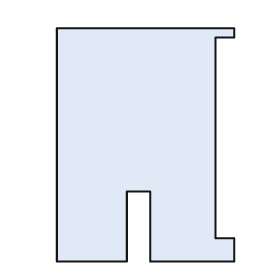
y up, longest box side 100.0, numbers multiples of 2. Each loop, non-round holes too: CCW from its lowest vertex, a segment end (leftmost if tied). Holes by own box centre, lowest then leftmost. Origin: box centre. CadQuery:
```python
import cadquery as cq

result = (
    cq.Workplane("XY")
    .moveTo(-38.0, -50.0)
    .lineTo(-8.0, -50.0)
    .lineTo(-8.0, -20.0)
    .lineTo(2.0, -20.0)
    .lineTo(2.0, -50.0)
    .lineTo(38.0, -50.0)
    .lineTo(38.0, -40.0)
    .lineTo(30.0, -40.0)
    .lineTo(30.0, 46.0)
    .lineTo(38.0, 46.0)
    .lineTo(38.0, 50.0)
    .lineTo(-38.0, 50.0)
    .close()
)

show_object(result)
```